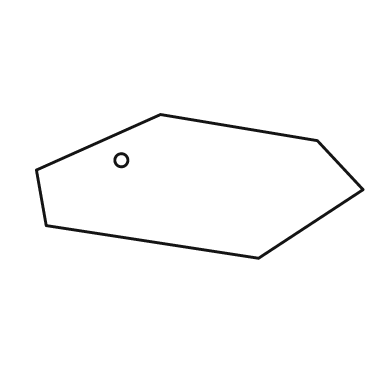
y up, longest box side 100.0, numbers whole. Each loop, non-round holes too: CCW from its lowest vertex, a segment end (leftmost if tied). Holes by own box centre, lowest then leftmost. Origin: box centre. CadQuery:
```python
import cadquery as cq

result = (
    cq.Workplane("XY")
    .moveTo(18.0, -22.0)
    .lineTo(50.0, -1.0)
    .lineTo(36.0, 14.0)
    .lineTo(-12.0, 22.0)
    .lineTo(-50.0, 5.0)
    .lineTo(-47.0, -12.0)
    .close()
    .moveTo(-24.0, 8.0)
    .circle(2.0)
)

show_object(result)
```